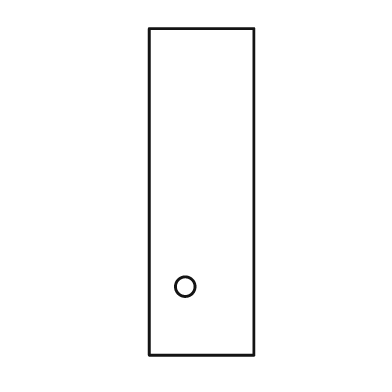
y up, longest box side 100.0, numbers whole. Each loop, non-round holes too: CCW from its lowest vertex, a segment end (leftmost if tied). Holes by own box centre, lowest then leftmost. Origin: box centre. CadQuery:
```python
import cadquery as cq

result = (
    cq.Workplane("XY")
    .moveTo(-16.0, -50.0)
    .lineTo(16.0, -50.0)
    .lineTo(16.0, 50.0)
    .lineTo(-16.0, 50.0)
    .close()
    .moveTo(-5.0, -29.0)
    .circle(3.0)
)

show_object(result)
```